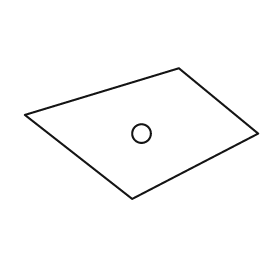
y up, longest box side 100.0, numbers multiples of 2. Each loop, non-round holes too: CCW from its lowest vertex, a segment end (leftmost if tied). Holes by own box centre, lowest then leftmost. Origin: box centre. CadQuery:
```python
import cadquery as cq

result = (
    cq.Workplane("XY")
    .moveTo(-4.0, -28.0)
    .lineTo(50.0, 0.0)
    .lineTo(16.0, 28.0)
    .lineTo(-50.0, 8.0)
    .close()
    .moveTo(0.0, 0.0)
    .circle(4.0)
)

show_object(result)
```